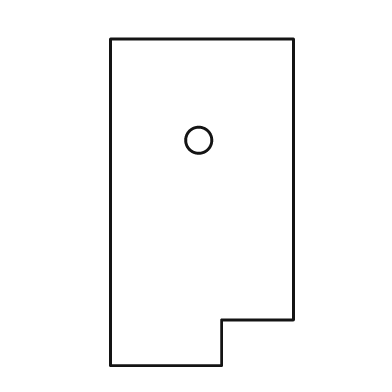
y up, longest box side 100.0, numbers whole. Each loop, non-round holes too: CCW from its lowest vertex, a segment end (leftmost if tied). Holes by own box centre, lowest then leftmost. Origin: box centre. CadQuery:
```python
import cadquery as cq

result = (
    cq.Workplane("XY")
    .moveTo(-28.0, -50.0)
    .lineTo(6.0, -50.0)
    .lineTo(6.0, -36.0)
    .lineTo(28.0, -36.0)
    .lineTo(28.0, 50.0)
    .lineTo(-28.0, 50.0)
    .close()
    .moveTo(-1.0, 19.0)
    .circle(4.0)
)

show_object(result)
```